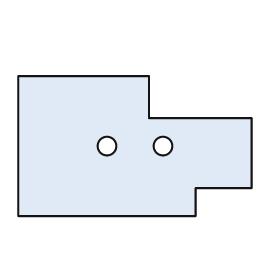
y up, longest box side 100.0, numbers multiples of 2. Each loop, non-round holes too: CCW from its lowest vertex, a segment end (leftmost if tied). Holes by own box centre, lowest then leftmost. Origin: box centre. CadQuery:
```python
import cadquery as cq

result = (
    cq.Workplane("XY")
    .moveTo(-50.0, -30.0)
    .lineTo(26.0, -30.0)
    .lineTo(26.0, -18.0)
    .lineTo(50.0, -18.0)
    .lineTo(50.0, 12.0)
    .lineTo(6.0, 12.0)
    .lineTo(6.0, 30.0)
    .lineTo(-50.0, 30.0)
    .close()
    .moveTo(-12.0, 0.0)
    .circle(4.0)
    .moveTo(12.0, 0.0)
    .circle(4.0)
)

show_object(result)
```